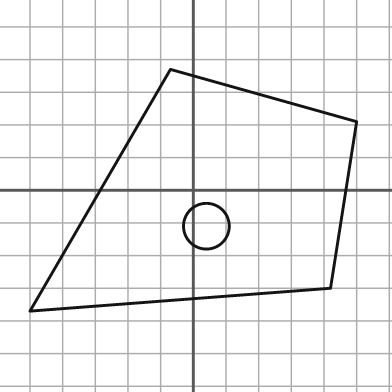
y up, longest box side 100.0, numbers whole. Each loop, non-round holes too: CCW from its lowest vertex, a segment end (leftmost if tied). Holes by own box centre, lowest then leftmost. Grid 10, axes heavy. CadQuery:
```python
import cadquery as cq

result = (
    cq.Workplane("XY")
    .moveTo(-50.0, -37.0)
    .lineTo(42.0, -30.0)
    .lineTo(50.0, 21.0)
    .lineTo(-7.0, 37.0)
    .close()
    .moveTo(4.0, -11.0)
    .circle(7.0)
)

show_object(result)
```